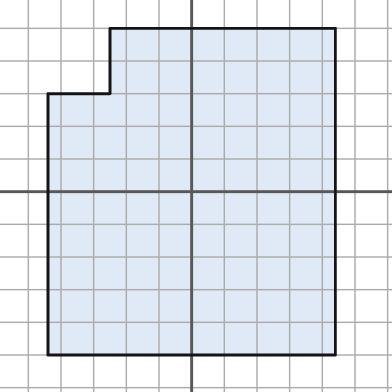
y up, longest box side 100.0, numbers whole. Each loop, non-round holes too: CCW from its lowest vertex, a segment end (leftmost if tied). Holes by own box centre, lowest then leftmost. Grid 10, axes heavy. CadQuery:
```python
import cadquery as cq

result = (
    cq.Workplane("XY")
    .moveTo(-44.0, -50.0)
    .lineTo(44.0, -50.0)
    .lineTo(44.0, 50.0)
    .lineTo(-25.0, 50.0)
    .lineTo(-25.0, 30.0)
    .lineTo(-44.0, 30.0)
    .close()
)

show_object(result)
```